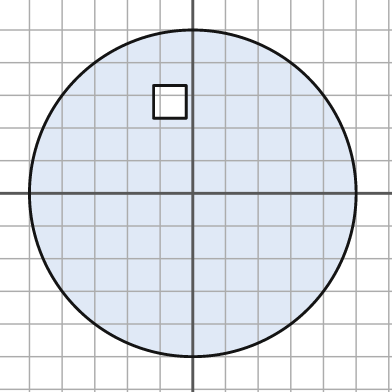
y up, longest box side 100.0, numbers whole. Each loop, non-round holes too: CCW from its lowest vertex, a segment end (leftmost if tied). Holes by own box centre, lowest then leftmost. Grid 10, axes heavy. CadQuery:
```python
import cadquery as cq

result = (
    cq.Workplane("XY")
    .moveTo(0.0, 0.0)
    .circle(50.0)
    .moveTo(-12.0, 23.0)
    .lineTo(-2.0, 23.0)
    .lineTo(-2.0, 33.0)
    .lineTo(-12.0, 33.0)
    .close()
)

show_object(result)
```